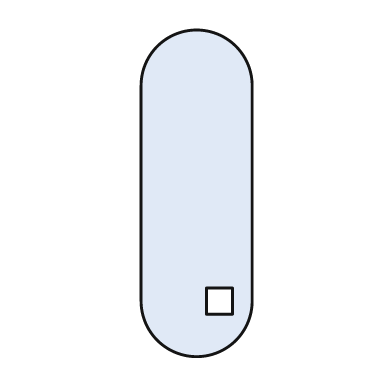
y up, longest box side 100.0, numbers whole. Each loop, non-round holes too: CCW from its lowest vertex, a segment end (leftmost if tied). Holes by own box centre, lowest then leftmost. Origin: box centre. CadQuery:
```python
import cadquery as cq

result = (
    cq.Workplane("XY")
    .moveTo(-17.0, -33.0)
    .threePointArc((0.0, -50.0), (17.0, -33.0))
    .lineTo(17.0, 33.0)
    .threePointArc((0.0, 50.0), (-17.0, 33.0))
    .close()
    .moveTo(3.0, -37.0)
    .lineTo(11.0, -37.0)
    .lineTo(11.0, -29.0)
    .lineTo(3.0, -29.0)
    .close()
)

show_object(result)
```